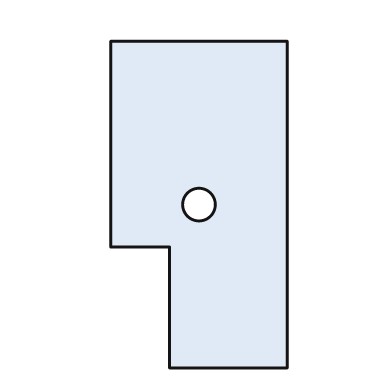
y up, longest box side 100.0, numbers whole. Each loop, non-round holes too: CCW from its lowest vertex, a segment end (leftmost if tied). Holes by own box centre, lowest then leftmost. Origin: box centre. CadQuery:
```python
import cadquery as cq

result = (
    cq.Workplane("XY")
    .moveTo(-9.0, -50.0)
    .lineTo(27.0, -50.0)
    .lineTo(27.0, 50.0)
    .lineTo(-27.0, 50.0)
    .lineTo(-27.0, -13.0)
    .lineTo(-9.0, -13.0)
    .close()
    .moveTo(0.0, 0.0)
    .circle(5.0)
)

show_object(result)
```